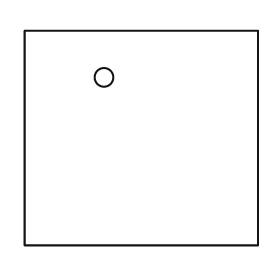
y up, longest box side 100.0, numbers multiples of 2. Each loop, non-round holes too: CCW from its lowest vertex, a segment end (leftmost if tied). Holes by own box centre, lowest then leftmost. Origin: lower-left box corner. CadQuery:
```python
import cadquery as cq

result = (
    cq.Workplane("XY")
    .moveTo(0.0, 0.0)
    .lineTo(100.0, 0.0)
    .lineTo(100.0, 92.0)
    .lineTo(0.0, 92.0)
    .close()
    .moveTo(34.0, 72.0)
    .circle(4.0)
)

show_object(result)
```